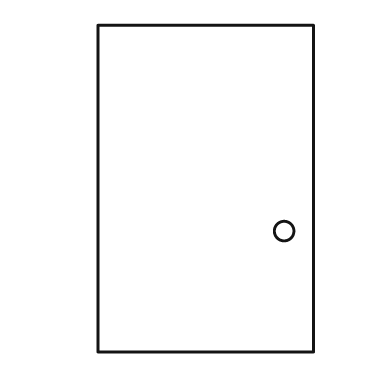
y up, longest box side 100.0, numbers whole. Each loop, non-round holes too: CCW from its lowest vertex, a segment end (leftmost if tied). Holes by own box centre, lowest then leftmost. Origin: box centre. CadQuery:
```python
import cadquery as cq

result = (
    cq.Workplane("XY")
    .moveTo(-33.0, -50.0)
    .lineTo(33.0, -50.0)
    .lineTo(33.0, 50.0)
    .lineTo(-33.0, 50.0)
    .close()
    .moveTo(24.0, -13.0)
    .circle(3.0)
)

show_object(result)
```